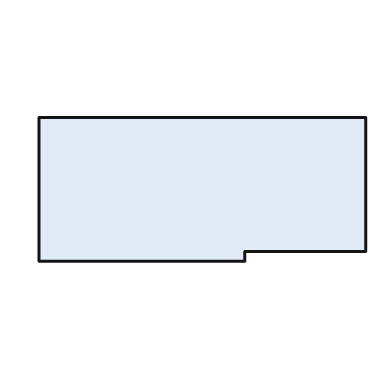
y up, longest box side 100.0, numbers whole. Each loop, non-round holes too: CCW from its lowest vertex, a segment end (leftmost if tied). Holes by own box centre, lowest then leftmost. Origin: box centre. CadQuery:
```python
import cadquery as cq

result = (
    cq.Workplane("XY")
    .moveTo(-50.0, -22.0)
    .lineTo(13.0, -22.0)
    .lineTo(13.0, -19.0)
    .lineTo(50.0, -19.0)
    .lineTo(50.0, 22.0)
    .lineTo(-50.0, 22.0)
    .close()
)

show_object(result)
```